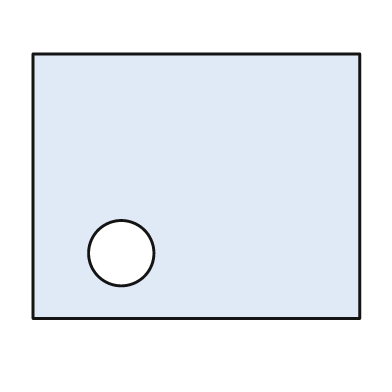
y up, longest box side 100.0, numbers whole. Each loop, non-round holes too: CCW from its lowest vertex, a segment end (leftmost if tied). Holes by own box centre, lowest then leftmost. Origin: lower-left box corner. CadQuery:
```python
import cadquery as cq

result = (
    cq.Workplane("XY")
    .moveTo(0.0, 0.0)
    .lineTo(100.0, 0.0)
    .lineTo(100.0, 81.0)
    .lineTo(0.0, 81.0)
    .close()
    .moveTo(27.0, 20.0)
    .circle(10.0)
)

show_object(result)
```